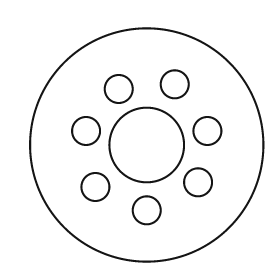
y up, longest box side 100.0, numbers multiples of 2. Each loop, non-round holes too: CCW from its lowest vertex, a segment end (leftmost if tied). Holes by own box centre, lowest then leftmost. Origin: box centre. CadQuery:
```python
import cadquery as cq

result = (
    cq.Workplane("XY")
    .moveTo(0.0, 0.0)
    .circle(50.0)
    .moveTo(0.0, -28.0)
    .circle(6.0)
    .moveTo(-22.0, -18.0)
    .circle(6.0)
    .moveTo(22.0, -16.0)
    .circle(6.0)
    .moveTo(0.0, 0.0)
    .circle(16.0)
    .moveTo(-26.0, 6.0)
    .circle(6.0)
    .moveTo(26.0, 6.0)
    .circle(6.0)
    .moveTo(-12.0, 24.0)
    .circle(6.0)
    .moveTo(12.0, 26.0)
    .circle(6.0)
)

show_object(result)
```